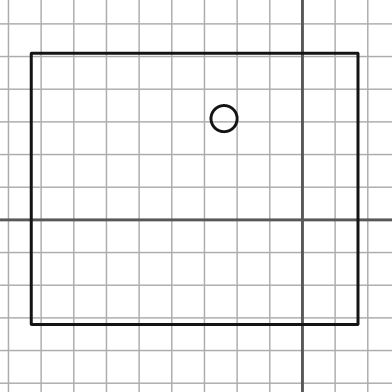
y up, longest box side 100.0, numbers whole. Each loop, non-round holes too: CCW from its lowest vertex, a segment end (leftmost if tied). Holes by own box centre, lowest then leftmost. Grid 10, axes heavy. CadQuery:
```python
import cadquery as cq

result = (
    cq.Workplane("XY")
    .moveTo(-83.0, -32.0)
    .lineTo(17.0, -32.0)
    .lineTo(17.0, 51.0)
    .lineTo(-83.0, 51.0)
    .close()
    .moveTo(-24.0, 31.0)
    .circle(4.0)
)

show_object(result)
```